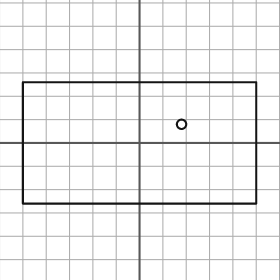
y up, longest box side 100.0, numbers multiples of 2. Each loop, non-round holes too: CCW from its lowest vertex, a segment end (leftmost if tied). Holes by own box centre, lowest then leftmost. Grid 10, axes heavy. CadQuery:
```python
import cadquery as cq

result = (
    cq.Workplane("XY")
    .moveTo(-50.0, -26.0)
    .lineTo(50.0, -26.0)
    .lineTo(50.0, 26.0)
    .lineTo(-50.0, 26.0)
    .close()
    .moveTo(18.0, 8.0)
    .circle(2.0)
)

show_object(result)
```